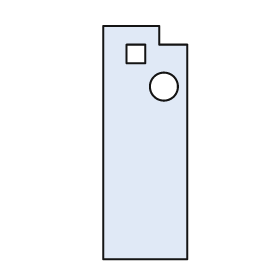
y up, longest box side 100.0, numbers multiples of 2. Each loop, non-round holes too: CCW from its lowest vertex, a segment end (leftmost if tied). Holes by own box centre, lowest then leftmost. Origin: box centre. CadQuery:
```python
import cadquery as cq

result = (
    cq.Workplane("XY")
    .moveTo(-18.0, -50.0)
    .lineTo(18.0, -50.0)
    .lineTo(18.0, 42.0)
    .lineTo(6.0, 42.0)
    .lineTo(6.0, 50.0)
    .lineTo(-18.0, 50.0)
    .close()
    .moveTo(8.0, 24.0)
    .circle(6.0)
    .moveTo(-8.0, 34.0)
    .lineTo(0.0, 34.0)
    .lineTo(0.0, 42.0)
    .lineTo(-8.0, 42.0)
    .close()
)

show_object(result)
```